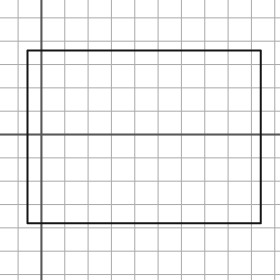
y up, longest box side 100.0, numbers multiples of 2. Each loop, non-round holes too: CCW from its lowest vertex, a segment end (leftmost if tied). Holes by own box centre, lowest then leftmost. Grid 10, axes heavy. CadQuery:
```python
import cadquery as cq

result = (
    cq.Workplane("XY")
    .moveTo(-6.0, -38.0)
    .lineTo(94.0, -38.0)
    .lineTo(94.0, 36.0)
    .lineTo(-6.0, 36.0)
    .close()
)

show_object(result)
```